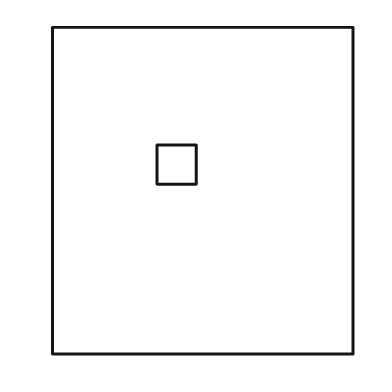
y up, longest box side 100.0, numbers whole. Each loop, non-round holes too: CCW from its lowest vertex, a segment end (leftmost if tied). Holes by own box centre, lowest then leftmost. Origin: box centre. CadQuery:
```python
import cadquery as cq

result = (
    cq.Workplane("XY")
    .moveTo(-46.0, -50.0)
    .lineTo(46.0, -50.0)
    .lineTo(46.0, 50.0)
    .lineTo(-46.0, 50.0)
    .close()
    .moveTo(-14.0, 2.0)
    .lineTo(-2.0, 2.0)
    .lineTo(-2.0, 14.0)
    .lineTo(-14.0, 14.0)
    .close()
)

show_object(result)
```